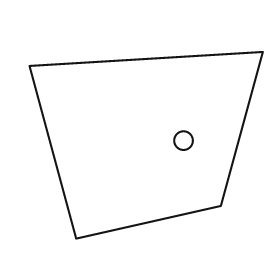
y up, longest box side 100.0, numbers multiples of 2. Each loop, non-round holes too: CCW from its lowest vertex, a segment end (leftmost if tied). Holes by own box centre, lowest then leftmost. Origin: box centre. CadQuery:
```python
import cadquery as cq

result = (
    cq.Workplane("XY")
    .moveTo(-30.0, -40.0)
    .lineTo(32.0, -26.0)
    .lineTo(50.0, 40.0)
    .lineTo(-50.0, 34.0)
    .close()
    .moveTo(16.0, 2.0)
    .circle(4.0)
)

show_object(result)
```